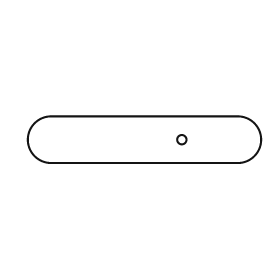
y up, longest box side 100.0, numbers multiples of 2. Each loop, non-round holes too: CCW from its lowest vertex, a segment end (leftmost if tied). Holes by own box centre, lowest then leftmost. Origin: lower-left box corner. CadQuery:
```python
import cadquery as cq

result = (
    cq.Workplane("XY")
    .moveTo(10.0, 0.0)
    .lineTo(90.0, 0.0)
    .threePointArc((100.0, 10.0), (90.0, 20.0))
    .lineTo(10.0, 20.0)
    .threePointArc((0.0, 10.0), (10.0, 0.0))
    .close()
    .moveTo(66.0, 10.0)
    .circle(2.0)
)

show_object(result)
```